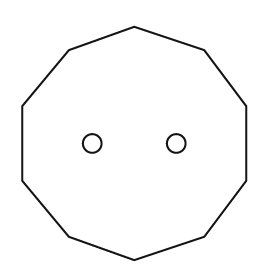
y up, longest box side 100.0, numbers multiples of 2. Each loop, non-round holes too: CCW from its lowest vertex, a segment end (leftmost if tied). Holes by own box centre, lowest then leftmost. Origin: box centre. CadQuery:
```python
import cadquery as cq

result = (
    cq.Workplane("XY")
    .moveTo(0.0, -50.0)
    .lineTo(30.0, -40.0)
    .lineTo(48.0, -16.0)
    .lineTo(48.0, 16.0)
    .lineTo(30.0, 40.0)
    .lineTo(0.0, 50.0)
    .lineTo(-28.0, 40.0)
    .lineTo(-48.0, 16.0)
    .lineTo(-48.0, -16.0)
    .lineTo(-28.0, -40.0)
    .close()
    .moveTo(-18.0, 0.0)
    .circle(4.0)
    .moveTo(18.0, 0.0)
    .circle(4.0)
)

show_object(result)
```